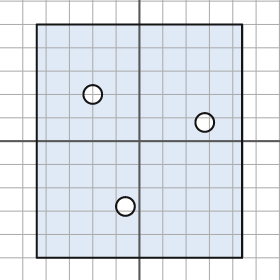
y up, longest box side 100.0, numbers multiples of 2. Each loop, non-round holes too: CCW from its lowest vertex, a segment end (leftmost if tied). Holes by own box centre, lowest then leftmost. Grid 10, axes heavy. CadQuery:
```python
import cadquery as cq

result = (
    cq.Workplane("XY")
    .moveTo(-44.0, -50.0)
    .lineTo(44.0, -50.0)
    .lineTo(44.0, 50.0)
    .lineTo(-44.0, 50.0)
    .close()
    .moveTo(-6.0, -28.0)
    .circle(4.0)
    .moveTo(28.0, 8.0)
    .circle(4.0)
    .moveTo(-20.0, 20.0)
    .circle(4.0)
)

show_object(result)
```